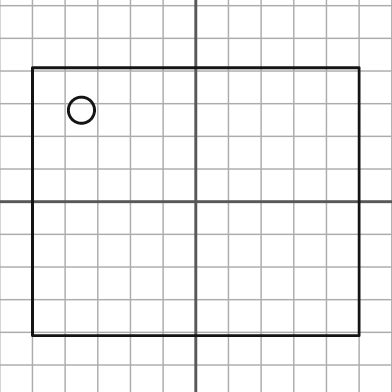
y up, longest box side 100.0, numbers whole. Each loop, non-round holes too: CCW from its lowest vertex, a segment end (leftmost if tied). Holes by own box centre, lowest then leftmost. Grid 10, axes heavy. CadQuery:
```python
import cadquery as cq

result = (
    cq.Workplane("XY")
    .moveTo(-50.0, -41.0)
    .lineTo(50.0, -41.0)
    .lineTo(50.0, 41.0)
    .lineTo(-50.0, 41.0)
    .close()
    .moveTo(-35.0, 28.0)
    .circle(4.0)
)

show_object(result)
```